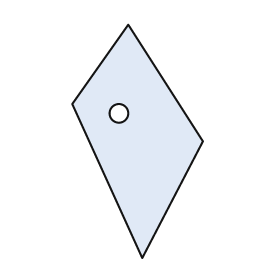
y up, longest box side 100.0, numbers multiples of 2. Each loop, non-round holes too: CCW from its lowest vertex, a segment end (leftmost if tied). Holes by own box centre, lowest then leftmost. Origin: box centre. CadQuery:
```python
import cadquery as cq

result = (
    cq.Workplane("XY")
    .moveTo(2.0, -50.0)
    .lineTo(28.0, 0.0)
    .lineTo(-4.0, 50.0)
    .lineTo(-28.0, 16.0)
    .close()
    .moveTo(-8.0, 12.0)
    .circle(4.0)
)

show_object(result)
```